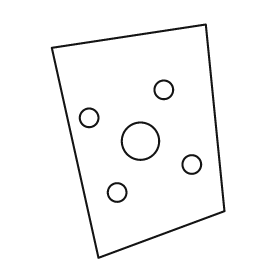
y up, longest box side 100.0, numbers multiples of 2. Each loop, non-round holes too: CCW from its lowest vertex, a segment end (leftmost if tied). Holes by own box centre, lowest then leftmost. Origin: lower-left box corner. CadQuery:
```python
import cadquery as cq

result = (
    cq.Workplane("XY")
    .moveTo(20.0, 0.0)
    .lineTo(74.0, 20.0)
    .lineTo(66.0, 100.0)
    .lineTo(0.0, 90.0)
    .close()
    .moveTo(28.0, 28.0)
    .circle(4.0)
    .moveTo(60.0, 40.0)
    .circle(4.0)
    .moveTo(38.0, 50.0)
    .circle(8.0)
    .moveTo(16.0, 60.0)
    .circle(4.0)
    .moveTo(48.0, 72.0)
    .circle(4.0)
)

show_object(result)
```